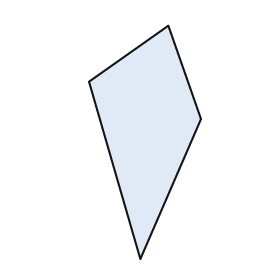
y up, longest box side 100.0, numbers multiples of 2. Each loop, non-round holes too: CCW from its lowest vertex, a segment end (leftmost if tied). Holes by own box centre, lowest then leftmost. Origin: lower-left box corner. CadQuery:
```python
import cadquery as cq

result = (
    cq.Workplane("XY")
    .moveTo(22.0, 0.0)
    .lineTo(48.0, 60.0)
    .lineTo(34.0, 100.0)
    .lineTo(0.0, 76.0)
    .close()
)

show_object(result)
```